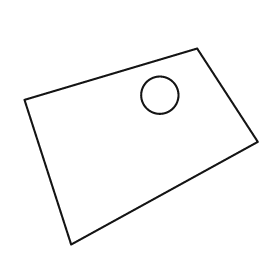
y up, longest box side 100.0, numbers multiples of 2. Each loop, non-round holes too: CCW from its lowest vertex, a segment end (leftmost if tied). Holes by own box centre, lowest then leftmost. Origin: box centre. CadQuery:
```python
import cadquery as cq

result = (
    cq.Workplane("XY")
    .moveTo(-30.0, -42.0)
    .lineTo(50.0, 2.0)
    .lineTo(24.0, 42.0)
    .lineTo(-50.0, 20.0)
    .close()
    .moveTo(8.0, 22.0)
    .circle(8.0)
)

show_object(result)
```